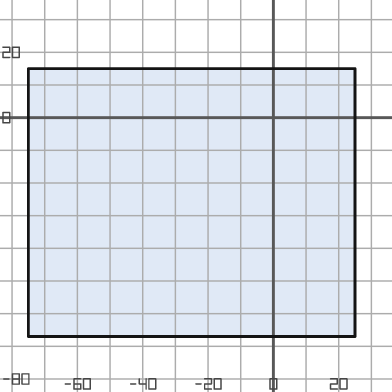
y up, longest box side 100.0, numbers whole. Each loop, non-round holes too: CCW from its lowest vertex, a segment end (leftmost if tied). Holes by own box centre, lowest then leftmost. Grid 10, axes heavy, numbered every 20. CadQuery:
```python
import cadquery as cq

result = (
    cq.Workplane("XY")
    .moveTo(-75.0, -67.0)
    .lineTo(25.0, -67.0)
    .lineTo(25.0, 15.0)
    .lineTo(-75.0, 15.0)
    .close()
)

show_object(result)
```